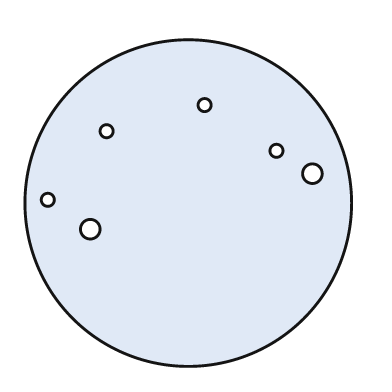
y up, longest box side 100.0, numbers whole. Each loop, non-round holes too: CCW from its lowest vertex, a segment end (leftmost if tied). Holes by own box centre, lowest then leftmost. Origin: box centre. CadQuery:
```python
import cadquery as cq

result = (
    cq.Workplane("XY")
    .moveTo(0.0, 0.0)
    .circle(50.0)
    .moveTo(-30.0, -8.0)
    .circle(3.0)
    .moveTo(-43.0, 1.0)
    .circle(2.0)
    .moveTo(38.0, 9.0)
    .circle(3.0)
    .moveTo(27.0, 16.0)
    .circle(2.0)
    .moveTo(-25.0, 22.0)
    .circle(2.0)
    .moveTo(5.0, 30.0)
    .circle(2.0)
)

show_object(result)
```